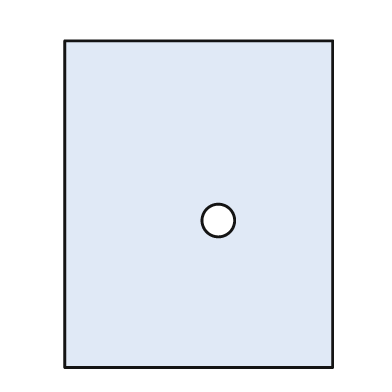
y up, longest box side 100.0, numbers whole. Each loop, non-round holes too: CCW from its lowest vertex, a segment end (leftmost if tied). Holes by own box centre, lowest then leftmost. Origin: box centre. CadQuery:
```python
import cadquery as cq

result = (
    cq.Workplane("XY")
    .moveTo(-41.0, -50.0)
    .lineTo(41.0, -50.0)
    .lineTo(41.0, 50.0)
    .lineTo(-41.0, 50.0)
    .close()
    .moveTo(6.0, -5.0)
    .circle(5.0)
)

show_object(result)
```